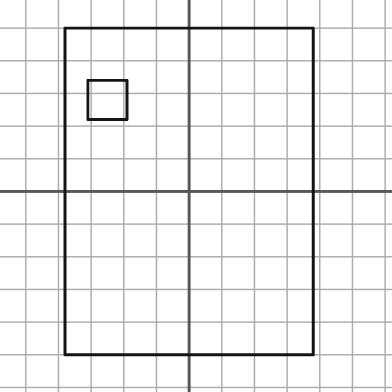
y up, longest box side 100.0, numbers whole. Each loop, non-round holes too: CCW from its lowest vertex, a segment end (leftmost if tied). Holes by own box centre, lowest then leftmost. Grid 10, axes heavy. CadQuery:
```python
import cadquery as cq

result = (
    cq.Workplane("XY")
    .moveTo(-38.0, -50.0)
    .lineTo(38.0, -50.0)
    .lineTo(38.0, 50.0)
    .lineTo(-38.0, 50.0)
    .close()
    .moveTo(-31.0, 22.0)
    .lineTo(-19.0, 22.0)
    .lineTo(-19.0, 34.0)
    .lineTo(-31.0, 34.0)
    .close()
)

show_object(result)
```